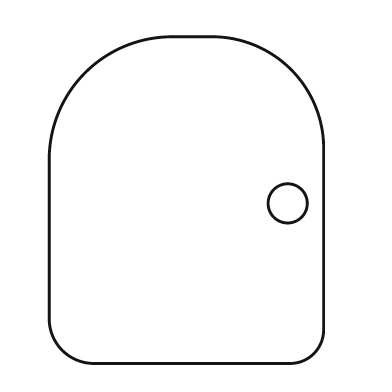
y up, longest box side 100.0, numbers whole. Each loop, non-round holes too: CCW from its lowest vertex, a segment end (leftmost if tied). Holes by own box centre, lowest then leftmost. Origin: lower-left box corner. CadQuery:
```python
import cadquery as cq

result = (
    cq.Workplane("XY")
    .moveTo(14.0, 0.0)
    .lineTo(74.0, 0.0)
    .threePointArc((81.0, 3.0), (84.0, 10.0))
    .lineTo(84.0, 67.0)
    .threePointArc((74.0, 90.0), (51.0, 100.0))
    .lineTo(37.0, 100.0)
    .threePointArc((11.0, 89.0), (0.0, 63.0))
    .lineTo(0.0, 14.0)
    .threePointArc((4.0, 4.0), (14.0, 0.0))
    .close()
    .moveTo(73.0, 49.0)
    .circle(6.0)
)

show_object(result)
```